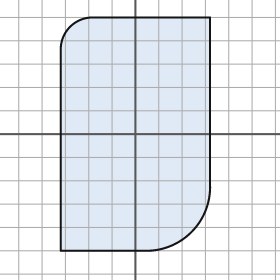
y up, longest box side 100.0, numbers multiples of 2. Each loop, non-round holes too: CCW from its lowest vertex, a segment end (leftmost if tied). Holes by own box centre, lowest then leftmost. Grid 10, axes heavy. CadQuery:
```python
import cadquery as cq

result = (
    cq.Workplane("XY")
    .moveTo(-32.0, -50.0)
    .lineTo(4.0, -50.0)
    .threePointArc((24.0, -42.0), (32.0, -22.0))
    .lineTo(32.0, 50.0)
    .lineTo(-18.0, 50.0)
    .threePointArc((-28.0, 46.0), (-32.0, 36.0))
    .close()
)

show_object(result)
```